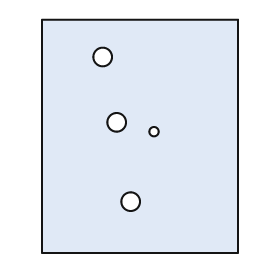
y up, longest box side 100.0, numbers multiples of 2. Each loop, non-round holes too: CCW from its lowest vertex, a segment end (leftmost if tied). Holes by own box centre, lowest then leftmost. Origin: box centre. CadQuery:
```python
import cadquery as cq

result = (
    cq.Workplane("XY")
    .moveTo(-42.0, -50.0)
    .lineTo(42.0, -50.0)
    .lineTo(42.0, 50.0)
    .lineTo(-42.0, 50.0)
    .close()
    .moveTo(-4.0, -28.0)
    .circle(4.0)
    .moveTo(6.0, 2.0)
    .circle(2.0)
    .moveTo(-10.0, 6.0)
    .circle(4.0)
    .moveTo(-16.0, 34.0)
    .circle(4.0)
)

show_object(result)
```